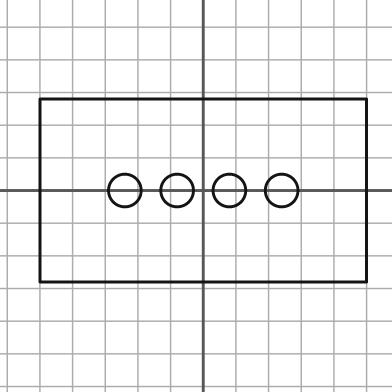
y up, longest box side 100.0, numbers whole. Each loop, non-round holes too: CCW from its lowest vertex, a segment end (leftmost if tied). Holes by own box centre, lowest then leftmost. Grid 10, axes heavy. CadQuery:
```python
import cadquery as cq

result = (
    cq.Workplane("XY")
    .moveTo(-50.0, -28.0)
    .lineTo(50.0, -28.0)
    .lineTo(50.0, 28.0)
    .lineTo(-50.0, 28.0)
    .close()
    .moveTo(-24.0, 0.0)
    .circle(5.0)
    .moveTo(-8.0, 0.0)
    .circle(5.0)
    .moveTo(8.0, 0.0)
    .circle(5.0)
    .moveTo(24.0, 0.0)
    .circle(5.0)
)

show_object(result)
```